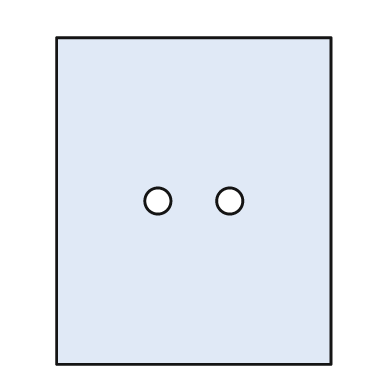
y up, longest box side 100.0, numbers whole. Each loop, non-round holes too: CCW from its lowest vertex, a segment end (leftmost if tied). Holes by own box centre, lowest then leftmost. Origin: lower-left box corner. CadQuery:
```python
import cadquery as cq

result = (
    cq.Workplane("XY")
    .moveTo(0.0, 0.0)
    .lineTo(84.0, 0.0)
    .lineTo(84.0, 100.0)
    .lineTo(0.0, 100.0)
    .close()
    .moveTo(31.0, 50.0)
    .circle(4.0)
    .moveTo(53.0, 50.0)
    .circle(4.0)
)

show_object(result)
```